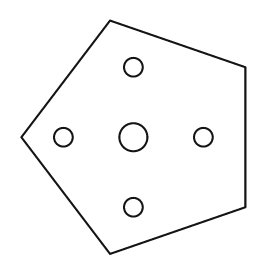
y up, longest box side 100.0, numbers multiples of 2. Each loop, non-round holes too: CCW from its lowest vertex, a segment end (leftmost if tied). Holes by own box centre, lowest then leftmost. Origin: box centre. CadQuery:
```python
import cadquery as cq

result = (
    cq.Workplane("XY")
    .moveTo(-10.0, -50.0)
    .lineTo(48.0, -30.0)
    .lineTo(48.0, 30.0)
    .lineTo(-10.0, 50.0)
    .lineTo(-48.0, 0.0)
    .close()
    .moveTo(0.0, -30.0)
    .circle(4.0)
    .moveTo(-30.0, 0.0)
    .circle(4.0)
    .moveTo(0.0, 0.0)
    .circle(6.0)
    .moveTo(30.0, 0.0)
    .circle(4.0)
    .moveTo(0.0, 30.0)
    .circle(4.0)
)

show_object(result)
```